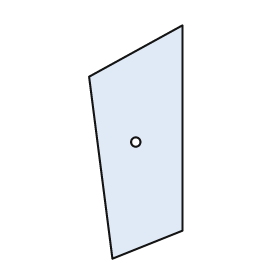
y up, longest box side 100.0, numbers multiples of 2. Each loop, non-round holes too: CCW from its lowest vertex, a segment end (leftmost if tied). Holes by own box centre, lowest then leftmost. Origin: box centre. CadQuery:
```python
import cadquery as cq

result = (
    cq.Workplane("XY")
    .moveTo(-10.0, -50.0)
    .lineTo(20.0, -38.0)
    .lineTo(20.0, 50.0)
    .lineTo(-20.0, 28.0)
    .close()
    .moveTo(0.0, 0.0)
    .circle(2.0)
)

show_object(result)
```